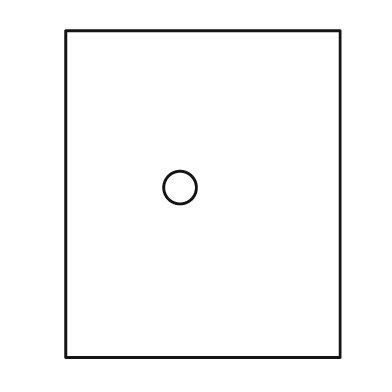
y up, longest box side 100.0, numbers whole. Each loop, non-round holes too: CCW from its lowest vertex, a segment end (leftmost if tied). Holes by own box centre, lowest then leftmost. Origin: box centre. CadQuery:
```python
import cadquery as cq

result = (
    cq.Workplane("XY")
    .moveTo(-42.0, -50.0)
    .lineTo(42.0, -50.0)
    .lineTo(42.0, 50.0)
    .lineTo(-42.0, 50.0)
    .close()
    .moveTo(-7.0, 2.0)
    .circle(5.0)
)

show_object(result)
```